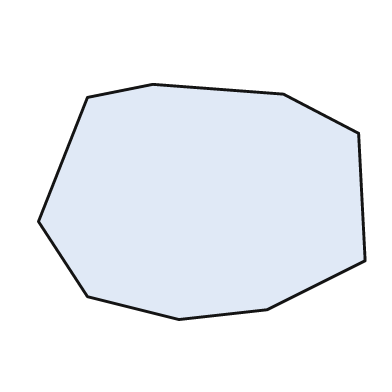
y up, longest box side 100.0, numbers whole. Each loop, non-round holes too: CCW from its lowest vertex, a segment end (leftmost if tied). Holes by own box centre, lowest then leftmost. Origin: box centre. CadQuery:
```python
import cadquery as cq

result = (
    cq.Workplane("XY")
    .moveTo(-7.0, -36.0)
    .lineTo(20.0, -33.0)
    .lineTo(50.0, -18.0)
    .lineTo(48.0, 21.0)
    .lineTo(25.0, 33.0)
    .lineTo(-15.0, 36.0)
    .lineTo(-35.0, 32.0)
    .lineTo(-50.0, -6.0)
    .lineTo(-35.0, -29.0)
    .close()
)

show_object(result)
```